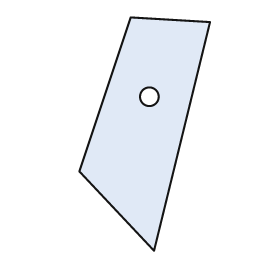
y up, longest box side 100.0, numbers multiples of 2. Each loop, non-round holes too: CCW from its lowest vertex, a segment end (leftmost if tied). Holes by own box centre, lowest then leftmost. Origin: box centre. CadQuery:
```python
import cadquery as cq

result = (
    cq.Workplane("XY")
    .moveTo(4.0, -50.0)
    .lineTo(28.0, 48.0)
    .lineTo(-6.0, 50.0)
    .lineTo(-28.0, -16.0)
    .close()
    .moveTo(2.0, 16.0)
    .circle(4.0)
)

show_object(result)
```